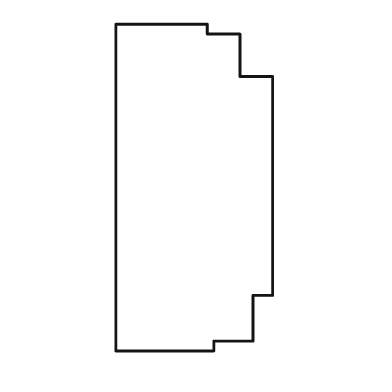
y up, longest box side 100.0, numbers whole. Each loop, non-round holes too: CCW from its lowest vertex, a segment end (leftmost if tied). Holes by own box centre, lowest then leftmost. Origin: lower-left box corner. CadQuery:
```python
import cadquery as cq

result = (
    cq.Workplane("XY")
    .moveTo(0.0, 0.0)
    .lineTo(30.0, 0.0)
    .lineTo(30.0, 3.0)
    .lineTo(42.0, 3.0)
    .lineTo(42.0, 17.0)
    .lineTo(48.0, 17.0)
    .lineTo(48.0, 84.0)
    .lineTo(38.0, 84.0)
    .lineTo(38.0, 97.0)
    .lineTo(28.0, 97.0)
    .lineTo(28.0, 100.0)
    .lineTo(0.0, 100.0)
    .close()
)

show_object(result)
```